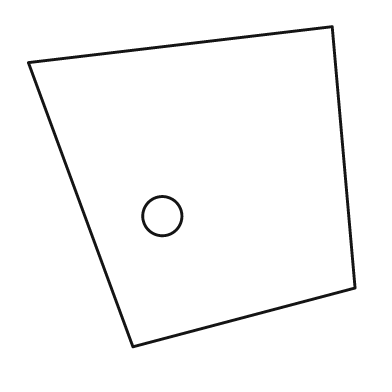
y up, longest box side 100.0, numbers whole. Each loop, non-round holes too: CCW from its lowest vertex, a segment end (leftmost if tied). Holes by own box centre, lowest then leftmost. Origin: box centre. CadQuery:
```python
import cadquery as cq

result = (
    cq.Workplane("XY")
    .moveTo(-18.0, -49.0)
    .lineTo(50.0, -31.0)
    .lineTo(43.0, 49.0)
    .lineTo(-50.0, 38.0)
    .close()
    .moveTo(-9.0, -9.0)
    .circle(6.0)
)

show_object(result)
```